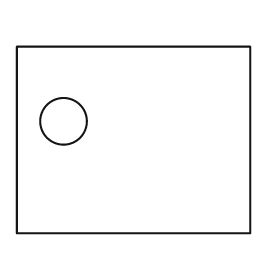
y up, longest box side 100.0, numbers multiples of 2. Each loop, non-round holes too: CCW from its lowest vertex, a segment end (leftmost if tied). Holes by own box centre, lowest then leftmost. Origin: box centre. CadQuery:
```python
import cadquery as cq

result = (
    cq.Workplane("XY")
    .moveTo(-50.0, -40.0)
    .lineTo(50.0, -40.0)
    .lineTo(50.0, 40.0)
    .lineTo(-50.0, 40.0)
    .close()
    .moveTo(-30.0, 8.0)
    .circle(10.0)
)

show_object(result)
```